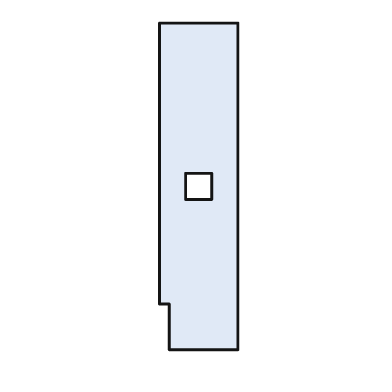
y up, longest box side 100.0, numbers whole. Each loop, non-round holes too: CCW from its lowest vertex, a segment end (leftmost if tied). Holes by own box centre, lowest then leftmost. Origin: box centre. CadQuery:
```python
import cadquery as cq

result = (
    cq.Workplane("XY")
    .moveTo(-9.0, -50.0)
    .lineTo(12.0, -50.0)
    .lineTo(12.0, 50.0)
    .lineTo(-12.0, 50.0)
    .lineTo(-12.0, -36.0)
    .lineTo(-9.0, -36.0)
    .close()
    .moveTo(-4.0, -4.0)
    .lineTo(4.0, -4.0)
    .lineTo(4.0, 4.0)
    .lineTo(-4.0, 4.0)
    .close()
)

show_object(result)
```